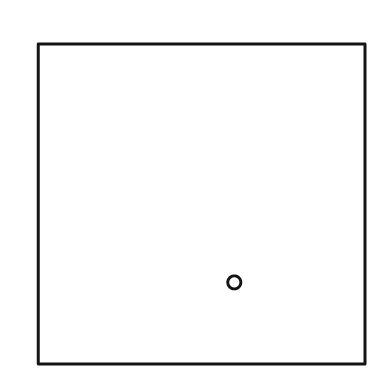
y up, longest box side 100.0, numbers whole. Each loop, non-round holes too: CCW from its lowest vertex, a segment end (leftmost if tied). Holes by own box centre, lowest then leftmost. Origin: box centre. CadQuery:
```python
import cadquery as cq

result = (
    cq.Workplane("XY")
    .moveTo(-50.0, -49.0)
    .lineTo(50.0, -49.0)
    .lineTo(50.0, 49.0)
    .lineTo(-50.0, 49.0)
    .close()
    .moveTo(10.0, -24.0)
    .circle(2.0)
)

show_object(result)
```